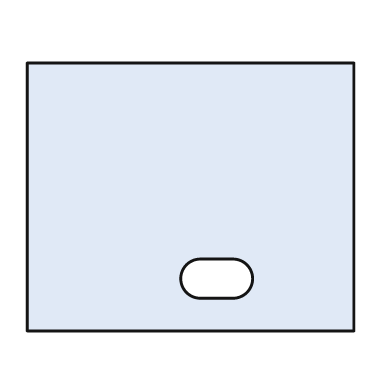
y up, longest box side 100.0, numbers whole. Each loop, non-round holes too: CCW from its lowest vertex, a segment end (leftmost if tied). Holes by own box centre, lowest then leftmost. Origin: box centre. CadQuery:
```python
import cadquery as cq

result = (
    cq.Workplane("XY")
    .moveTo(-50.0, -41.0)
    .lineTo(50.0, -41.0)
    .lineTo(50.0, 41.0)
    .lineTo(-50.0, 41.0)
    .close()
    .moveTo(3.0, -31.0)
    .lineTo(13.0, -31.0)
    .threePointArc((19.0, -25.0), (13.0, -19.0))
    .lineTo(3.0, -19.0)
    .threePointArc((-3.0, -25.0), (3.0, -31.0))
    .close()
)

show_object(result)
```